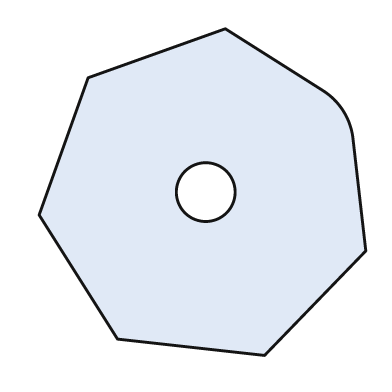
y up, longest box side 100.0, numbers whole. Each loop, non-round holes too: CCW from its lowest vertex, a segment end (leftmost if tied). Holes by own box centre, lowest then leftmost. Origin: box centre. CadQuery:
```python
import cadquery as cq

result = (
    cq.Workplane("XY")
    .moveTo(19.0, -50.0)
    .lineTo(50.0, -18.0)
    .lineTo(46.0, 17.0)
    .threePointArc((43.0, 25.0), (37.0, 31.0))
    .lineTo(7.0, 50.0)
    .lineTo(-35.0, 35.0)
    .lineTo(-50.0, -7.0)
    .lineTo(-26.0, -45.0)
    .close()
    .moveTo(1.0, 0.0)
    .circle(9.0)
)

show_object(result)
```